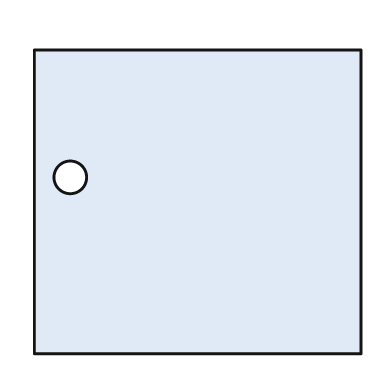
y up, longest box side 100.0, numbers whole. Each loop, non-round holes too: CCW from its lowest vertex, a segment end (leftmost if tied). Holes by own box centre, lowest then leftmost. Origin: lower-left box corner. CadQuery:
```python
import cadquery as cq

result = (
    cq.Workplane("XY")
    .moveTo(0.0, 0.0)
    .lineTo(100.0, 0.0)
    .lineTo(100.0, 93.0)
    .lineTo(0.0, 93.0)
    .close()
    .moveTo(11.0, 54.0)
    .circle(5.0)
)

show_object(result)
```